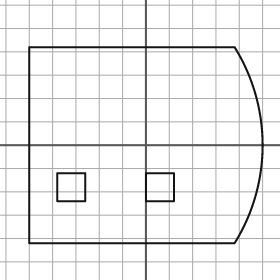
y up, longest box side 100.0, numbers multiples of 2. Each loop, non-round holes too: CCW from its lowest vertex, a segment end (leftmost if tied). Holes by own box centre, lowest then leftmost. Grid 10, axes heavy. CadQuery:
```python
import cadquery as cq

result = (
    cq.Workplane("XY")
    .moveTo(-50.0, -42.0)
    .lineTo(38.0, -42.0)
    .threePointArc((50.0, 0.0), (38.0, 42.0))
    .lineTo(-50.0, 42.0)
    .close()
    .moveTo(-38.0, -24.0)
    .lineTo(-26.0, -24.0)
    .lineTo(-26.0, -12.0)
    .lineTo(-38.0, -12.0)
    .close()
    .moveTo(0.0, -24.0)
    .lineTo(12.0, -24.0)
    .lineTo(12.0, -12.0)
    .lineTo(0.0, -12.0)
    .close()
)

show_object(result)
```